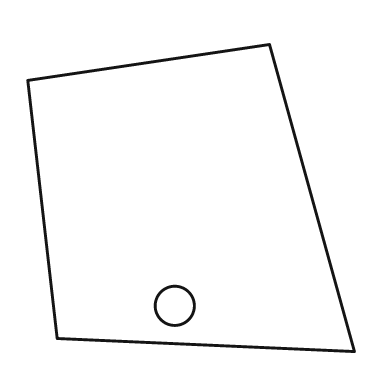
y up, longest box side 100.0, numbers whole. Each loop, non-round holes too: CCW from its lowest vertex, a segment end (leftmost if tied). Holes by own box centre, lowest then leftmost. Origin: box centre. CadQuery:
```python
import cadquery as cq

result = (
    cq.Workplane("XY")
    .moveTo(50.0, -47.0)
    .lineTo(24.0, 47.0)
    .lineTo(-50.0, 36.0)
    .lineTo(-41.0, -43.0)
    .close()
    .moveTo(-5.0, -33.0)
    .circle(6.0)
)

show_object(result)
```